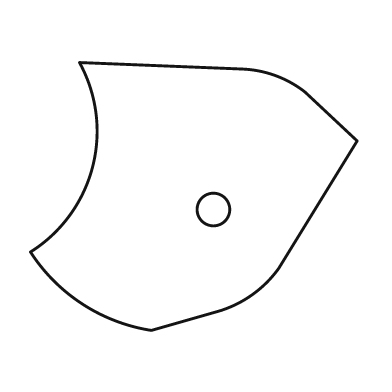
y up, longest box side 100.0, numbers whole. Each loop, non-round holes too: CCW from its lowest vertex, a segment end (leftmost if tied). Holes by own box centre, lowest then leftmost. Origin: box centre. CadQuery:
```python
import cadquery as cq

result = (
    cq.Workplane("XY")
    .moveTo(-13.0, -41.0)
    .lineTo(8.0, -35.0)
    .threePointArc((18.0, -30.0), (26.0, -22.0))
    .lineTo(50.0, 17.0)
    .lineTo(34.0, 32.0)
    .threePointArc((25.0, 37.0), (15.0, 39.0))
    .lineTo(-35.0, 41.0)
    .threePointArc((-31.0, 9.0), (-50.0, -17.0))
    .threePointArc((-34.0, -33.0), (-13.0, -41.0))
    .close()
    .moveTo(6.0, -4.0)
    .circle(5.0)
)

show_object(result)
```